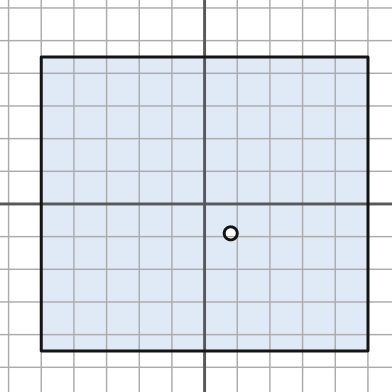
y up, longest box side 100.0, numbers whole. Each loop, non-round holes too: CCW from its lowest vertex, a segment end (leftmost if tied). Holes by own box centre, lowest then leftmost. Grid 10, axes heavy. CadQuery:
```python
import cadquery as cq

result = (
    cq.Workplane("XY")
    .moveTo(-50.0, -45.0)
    .lineTo(50.0, -45.0)
    .lineTo(50.0, 45.0)
    .lineTo(-50.0, 45.0)
    .close()
    .moveTo(8.0, -9.0)
    .circle(2.0)
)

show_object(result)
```